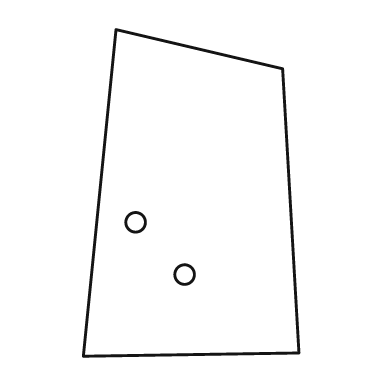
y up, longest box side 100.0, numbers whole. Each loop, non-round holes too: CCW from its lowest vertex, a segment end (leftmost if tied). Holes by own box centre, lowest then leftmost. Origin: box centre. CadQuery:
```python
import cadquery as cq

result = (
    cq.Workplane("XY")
    .moveTo(-33.0, -50.0)
    .lineTo(33.0, -49.0)
    .lineTo(28.0, 38.0)
    .lineTo(-23.0, 50.0)
    .close()
    .moveTo(-2.0, -25.0)
    .circle(3.0)
    .moveTo(-17.0, -9.0)
    .circle(3.0)
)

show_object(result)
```